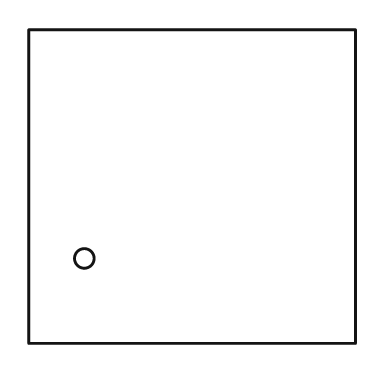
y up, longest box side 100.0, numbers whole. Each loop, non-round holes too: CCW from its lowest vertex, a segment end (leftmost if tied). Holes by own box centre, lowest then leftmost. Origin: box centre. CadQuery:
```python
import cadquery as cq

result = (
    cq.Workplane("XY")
    .moveTo(-50.0, -48.0)
    .lineTo(50.0, -48.0)
    .lineTo(50.0, 48.0)
    .lineTo(-50.0, 48.0)
    .close()
    .moveTo(-33.0, -22.0)
    .circle(3.0)
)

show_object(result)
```